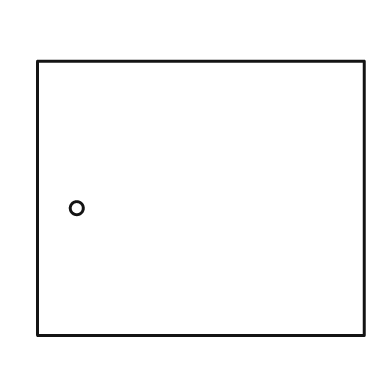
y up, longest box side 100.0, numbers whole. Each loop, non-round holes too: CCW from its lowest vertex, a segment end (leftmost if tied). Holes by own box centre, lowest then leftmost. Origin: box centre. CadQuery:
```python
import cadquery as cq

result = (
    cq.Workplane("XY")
    .moveTo(-50.0, -42.0)
    .lineTo(50.0, -42.0)
    .lineTo(50.0, 42.0)
    .lineTo(-50.0, 42.0)
    .close()
    .moveTo(-38.0, -3.0)
    .circle(2.0)
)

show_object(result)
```